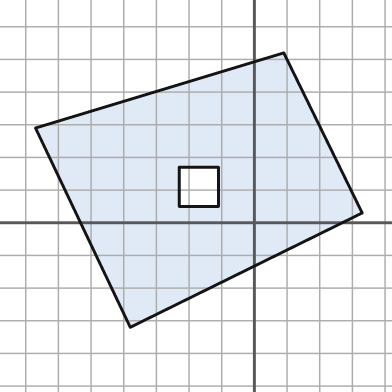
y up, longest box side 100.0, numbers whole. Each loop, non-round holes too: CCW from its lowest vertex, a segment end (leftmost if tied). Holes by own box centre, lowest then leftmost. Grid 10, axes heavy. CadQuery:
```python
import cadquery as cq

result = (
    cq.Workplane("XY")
    .moveTo(-38.0, -32.0)
    .lineTo(33.0, 3.0)
    .lineTo(9.0, 52.0)
    .lineTo(-67.0, 29.0)
    .close()
    .moveTo(-23.0, 5.0)
    .lineTo(-11.0, 5.0)
    .lineTo(-11.0, 17.0)
    .lineTo(-23.0, 17.0)
    .close()
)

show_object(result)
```